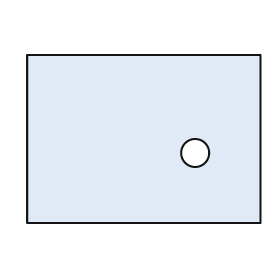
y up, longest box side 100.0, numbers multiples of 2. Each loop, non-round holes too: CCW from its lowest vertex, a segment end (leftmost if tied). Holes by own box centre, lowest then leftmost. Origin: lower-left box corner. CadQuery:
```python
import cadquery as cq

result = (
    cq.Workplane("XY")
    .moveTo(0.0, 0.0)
    .lineTo(100.0, 0.0)
    .lineTo(100.0, 72.0)
    .lineTo(0.0, 72.0)
    .close()
    .moveTo(72.0, 30.0)
    .circle(6.0)
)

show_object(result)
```